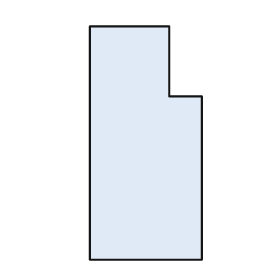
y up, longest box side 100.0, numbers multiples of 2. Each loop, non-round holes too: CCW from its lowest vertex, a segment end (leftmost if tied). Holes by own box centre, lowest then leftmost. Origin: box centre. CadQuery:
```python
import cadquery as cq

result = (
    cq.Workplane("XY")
    .moveTo(-24.0, -50.0)
    .lineTo(24.0, -50.0)
    .lineTo(24.0, 20.0)
    .lineTo(10.0, 20.0)
    .lineTo(10.0, 50.0)
    .lineTo(-24.0, 50.0)
    .close()
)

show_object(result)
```